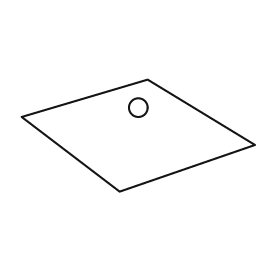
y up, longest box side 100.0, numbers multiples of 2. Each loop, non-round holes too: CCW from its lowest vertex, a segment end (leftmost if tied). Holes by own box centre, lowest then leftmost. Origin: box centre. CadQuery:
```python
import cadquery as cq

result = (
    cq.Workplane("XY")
    .moveTo(-8.0, -24.0)
    .lineTo(50.0, -4.0)
    .lineTo(4.0, 24.0)
    .lineTo(-50.0, 8.0)
    .close()
    .moveTo(0.0, 12.0)
    .circle(4.0)
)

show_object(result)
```